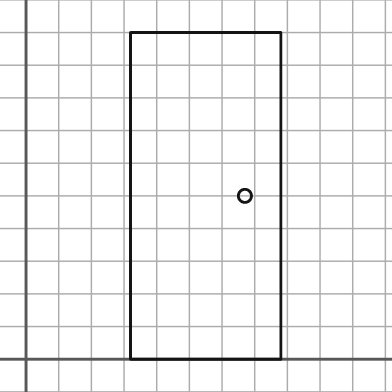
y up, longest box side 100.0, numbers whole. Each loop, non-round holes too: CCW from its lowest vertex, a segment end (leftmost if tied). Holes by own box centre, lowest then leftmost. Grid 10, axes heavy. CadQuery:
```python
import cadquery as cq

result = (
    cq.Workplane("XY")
    .moveTo(32.0, 0.0)
    .lineTo(78.0, 0.0)
    .lineTo(78.0, 100.0)
    .lineTo(32.0, 100.0)
    .close()
    .moveTo(67.0, 50.0)
    .circle(2.0)
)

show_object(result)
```